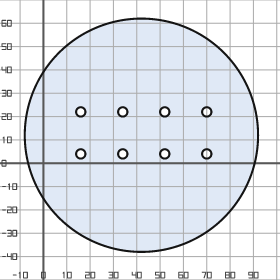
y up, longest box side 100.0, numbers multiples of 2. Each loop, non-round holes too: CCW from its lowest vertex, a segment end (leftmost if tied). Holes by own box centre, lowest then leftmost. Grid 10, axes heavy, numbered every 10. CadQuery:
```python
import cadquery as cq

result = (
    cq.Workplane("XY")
    .moveTo(42.0, 12.0)
    .circle(50.0)
    .moveTo(16.0, 4.0)
    .circle(2.0)
    .moveTo(34.0, 4.0)
    .circle(2.0)
    .moveTo(52.0, 4.0)
    .circle(2.0)
    .moveTo(70.0, 4.0)
    .circle(2.0)
    .moveTo(16.0, 22.0)
    .circle(2.0)
    .moveTo(34.0, 22.0)
    .circle(2.0)
    .moveTo(52.0, 22.0)
    .circle(2.0)
    .moveTo(70.0, 22.0)
    .circle(2.0)
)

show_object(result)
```